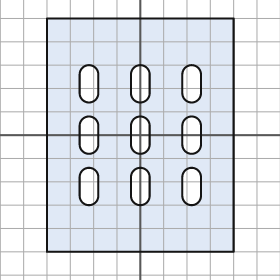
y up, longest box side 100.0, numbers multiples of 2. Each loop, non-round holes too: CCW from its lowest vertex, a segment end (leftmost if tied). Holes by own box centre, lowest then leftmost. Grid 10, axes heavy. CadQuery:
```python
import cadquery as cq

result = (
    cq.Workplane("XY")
    .moveTo(-40.0, -50.0)
    .lineTo(40.0, -50.0)
    .lineTo(40.0, 50.0)
    .lineTo(-40.0, 50.0)
    .close()
    .moveTo(-26.0, -26.0)
    .threePointArc((-22.0, -30.0), (-18.0, -26.0))
    .lineTo(-18.0, -18.0)
    .threePointArc((-22.0, -14.0), (-26.0, -18.0))
    .close()
    .moveTo(-4.0, -26.0)
    .threePointArc((0.0, -30.0), (4.0, -26.0))
    .lineTo(4.0, -18.0)
    .threePointArc((0.0, -14.0), (-4.0, -18.0))
    .close()
    .moveTo(18.0, -26.0)
    .threePointArc((22.0, -30.0), (26.0, -26.0))
    .lineTo(26.0, -18.0)
    .threePointArc((22.0, -14.0), (18.0, -18.0))
    .close()
    .moveTo(-26.0, -4.0)
    .threePointArc((-22.0, -8.0), (-18.0, -4.0))
    .lineTo(-18.0, 4.0)
    .threePointArc((-22.0, 8.0), (-26.0, 4.0))
    .close()
    .moveTo(-4.0, -4.0)
    .threePointArc((0.0, -8.0), (4.0, -4.0))
    .lineTo(4.0, 4.0)
    .threePointArc((0.0, 8.0), (-4.0, 4.0))
    .close()
    .moveTo(18.0, -4.0)
    .threePointArc((22.0, -8.0), (26.0, -4.0))
    .lineTo(26.0, 4.0)
    .threePointArc((22.0, 8.0), (18.0, 4.0))
    .close()
    .moveTo(-26.0, 18.0)
    .threePointArc((-22.0, 14.0), (-18.0, 18.0))
    .lineTo(-18.0, 26.0)
    .threePointArc((-22.0, 30.0), (-26.0, 26.0))
    .close()
    .moveTo(-4.0, 18.0)
    .threePointArc((0.0, 14.0), (4.0, 18.0))
    .lineTo(4.0, 26.0)
    .threePointArc((0.0, 30.0), (-4.0, 26.0))
    .close()
    .moveTo(18.0, 18.0)
    .threePointArc((22.0, 14.0), (26.0, 18.0))
    .lineTo(26.0, 26.0)
    .threePointArc((22.0, 30.0), (18.0, 26.0))
    .close()
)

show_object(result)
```